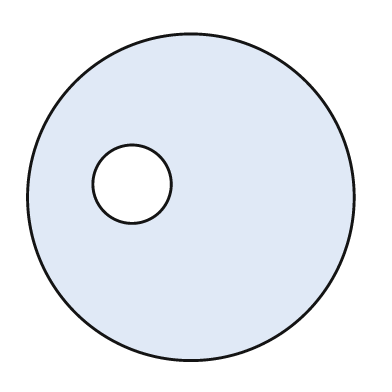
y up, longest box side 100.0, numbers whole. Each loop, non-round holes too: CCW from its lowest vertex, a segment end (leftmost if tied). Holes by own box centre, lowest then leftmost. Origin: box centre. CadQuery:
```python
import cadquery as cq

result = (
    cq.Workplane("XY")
    .moveTo(0.0, 0.0)
    .circle(50.0)
    .moveTo(-18.0, 4.0)
    .circle(12.0)
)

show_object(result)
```